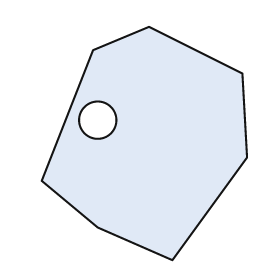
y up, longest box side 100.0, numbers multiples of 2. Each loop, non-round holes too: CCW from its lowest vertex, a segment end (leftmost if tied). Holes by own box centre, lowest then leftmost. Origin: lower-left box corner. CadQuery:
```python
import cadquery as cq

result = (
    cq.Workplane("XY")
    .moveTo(56.0, 0.0)
    .lineTo(88.0, 44.0)
    .lineTo(86.0, 80.0)
    .lineTo(46.0, 100.0)
    .lineTo(22.0, 90.0)
    .lineTo(0.0, 34.0)
    .lineTo(24.0, 14.0)
    .close()
    .moveTo(24.0, 60.0)
    .circle(8.0)
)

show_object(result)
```